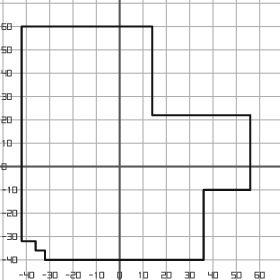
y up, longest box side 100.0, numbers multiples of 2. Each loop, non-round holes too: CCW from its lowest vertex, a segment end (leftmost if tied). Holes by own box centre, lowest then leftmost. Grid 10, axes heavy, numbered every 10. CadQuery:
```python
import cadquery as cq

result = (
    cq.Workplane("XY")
    .moveTo(-32.0, -40.0)
    .lineTo(36.0, -40.0)
    .lineTo(36.0, -10.0)
    .lineTo(56.0, -10.0)
    .lineTo(56.0, 22.0)
    .lineTo(14.0, 22.0)
    .lineTo(14.0, 60.0)
    .lineTo(-42.0, 60.0)
    .lineTo(-42.0, -32.0)
    .lineTo(-36.0, -32.0)
    .lineTo(-36.0, -36.0)
    .lineTo(-32.0, -36.0)
    .close()
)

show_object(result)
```